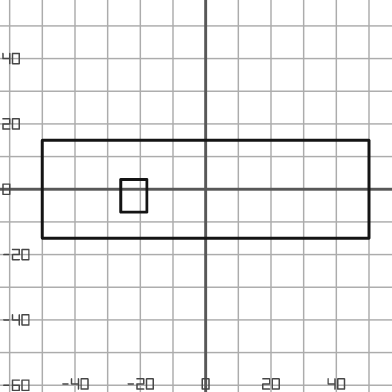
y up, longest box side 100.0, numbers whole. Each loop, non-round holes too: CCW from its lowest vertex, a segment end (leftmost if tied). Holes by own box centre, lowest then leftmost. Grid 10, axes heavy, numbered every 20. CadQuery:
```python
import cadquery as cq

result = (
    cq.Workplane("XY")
    .moveTo(-50.0, -15.0)
    .lineTo(50.0, -15.0)
    .lineTo(50.0, 15.0)
    .lineTo(-50.0, 15.0)
    .close()
    .moveTo(-26.0, -7.0)
    .lineTo(-18.0, -7.0)
    .lineTo(-18.0, 3.0)
    .lineTo(-26.0, 3.0)
    .close()
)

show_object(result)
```